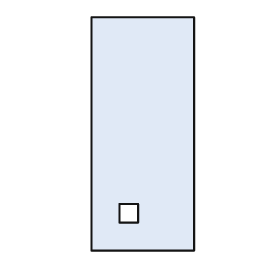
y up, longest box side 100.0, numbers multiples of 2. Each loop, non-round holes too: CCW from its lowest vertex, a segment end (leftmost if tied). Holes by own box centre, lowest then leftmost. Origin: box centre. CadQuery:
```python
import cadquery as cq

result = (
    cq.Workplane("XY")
    .moveTo(-22.0, -50.0)
    .lineTo(22.0, -50.0)
    .lineTo(22.0, 50.0)
    .lineTo(-22.0, 50.0)
    .close()
    .moveTo(-10.0, -38.0)
    .lineTo(-2.0, -38.0)
    .lineTo(-2.0, -30.0)
    .lineTo(-10.0, -30.0)
    .close()
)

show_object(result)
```